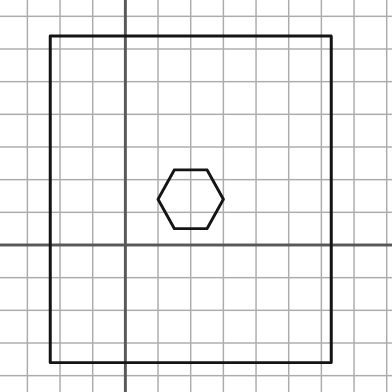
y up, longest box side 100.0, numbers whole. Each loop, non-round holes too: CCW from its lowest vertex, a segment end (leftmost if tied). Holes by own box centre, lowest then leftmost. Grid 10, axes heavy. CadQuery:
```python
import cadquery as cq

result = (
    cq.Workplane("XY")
    .moveTo(-23.0, -36.0)
    .lineTo(63.0, -36.0)
    .lineTo(63.0, 64.0)
    .lineTo(-23.0, 64.0)
    .close()
    .moveTo(15.0, 5.0)
    .lineTo(25.0, 5.0)
    .lineTo(30.0, 14.0)
    .lineTo(25.0, 23.0)
    .lineTo(15.0, 23.0)
    .lineTo(10.0, 14.0)
    .close()
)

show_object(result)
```